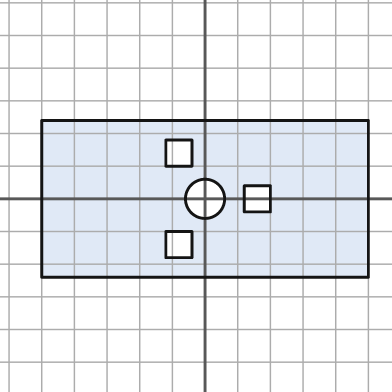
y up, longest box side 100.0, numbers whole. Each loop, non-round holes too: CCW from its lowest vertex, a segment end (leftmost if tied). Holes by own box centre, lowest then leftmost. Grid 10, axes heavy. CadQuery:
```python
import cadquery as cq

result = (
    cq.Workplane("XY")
    .moveTo(-50.0, -24.0)
    .lineTo(50.0, -24.0)
    .lineTo(50.0, 24.0)
    .lineTo(-50.0, 24.0)
    .close()
    .moveTo(-12.0, -18.0)
    .lineTo(-4.0, -18.0)
    .lineTo(-4.0, -10.0)
    .lineTo(-12.0, -10.0)
    .close()
    .moveTo(0.0, 0.0)
    .circle(6.0)
    .moveTo(12.0, -4.0)
    .lineTo(20.0, -4.0)
    .lineTo(20.0, 4.0)
    .lineTo(12.0, 4.0)
    .close()
    .moveTo(-12.0, 10.0)
    .lineTo(-4.0, 10.0)
    .lineTo(-4.0, 18.0)
    .lineTo(-12.0, 18.0)
    .close()
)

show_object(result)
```